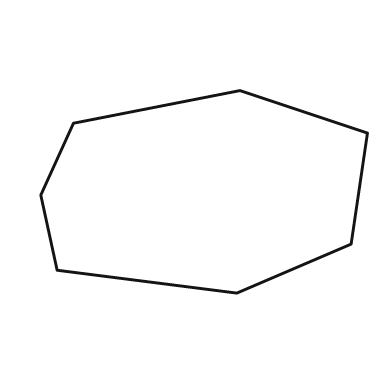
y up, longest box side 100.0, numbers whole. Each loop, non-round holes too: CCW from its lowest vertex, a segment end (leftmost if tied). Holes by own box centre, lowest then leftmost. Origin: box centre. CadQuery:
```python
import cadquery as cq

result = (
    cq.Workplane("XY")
    .moveTo(10.0, -31.0)
    .lineTo(45.0, -16.0)
    .lineTo(50.0, 18.0)
    .lineTo(11.0, 31.0)
    .lineTo(-40.0, 21.0)
    .lineTo(-50.0, -1.0)
    .lineTo(-45.0, -24.0)
    .close()
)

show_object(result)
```